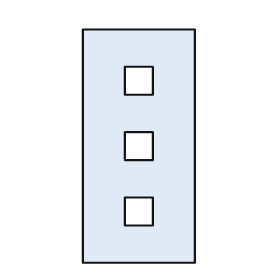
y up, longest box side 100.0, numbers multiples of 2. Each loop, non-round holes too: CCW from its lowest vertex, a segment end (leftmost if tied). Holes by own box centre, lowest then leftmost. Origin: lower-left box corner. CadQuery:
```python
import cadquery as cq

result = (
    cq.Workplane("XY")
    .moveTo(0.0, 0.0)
    .lineTo(48.0, 0.0)
    .lineTo(48.0, 100.0)
    .lineTo(0.0, 100.0)
    .close()
    .moveTo(18.0, 16.0)
    .lineTo(30.0, 16.0)
    .lineTo(30.0, 28.0)
    .lineTo(18.0, 28.0)
    .close()
    .moveTo(18.0, 44.0)
    .lineTo(30.0, 44.0)
    .lineTo(30.0, 56.0)
    .lineTo(18.0, 56.0)
    .close()
    .moveTo(18.0, 72.0)
    .lineTo(30.0, 72.0)
    .lineTo(30.0, 84.0)
    .lineTo(18.0, 84.0)
    .close()
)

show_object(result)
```